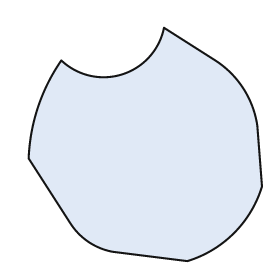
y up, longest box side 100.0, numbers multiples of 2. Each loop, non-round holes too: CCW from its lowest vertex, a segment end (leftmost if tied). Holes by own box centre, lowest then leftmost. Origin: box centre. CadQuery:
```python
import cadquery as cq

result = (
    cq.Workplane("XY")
    .moveTo(18.0, -50.0)
    .threePointArc((38.0, -38.0), (50.0, -18.0))
    .lineTo(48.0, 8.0)
    .threePointArc((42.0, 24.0), (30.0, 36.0))
    .lineTo(8.0, 50.0)
    .threePointArc((-10.0, 30.0), (-36.0, 36.0))
    .threePointArc((-46.0, 16.0), (-50.0, -6.0))
    .lineTo(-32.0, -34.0)
    .threePointArc((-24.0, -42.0), (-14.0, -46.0))
    .close()
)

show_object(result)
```